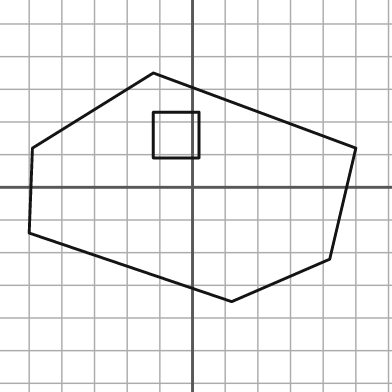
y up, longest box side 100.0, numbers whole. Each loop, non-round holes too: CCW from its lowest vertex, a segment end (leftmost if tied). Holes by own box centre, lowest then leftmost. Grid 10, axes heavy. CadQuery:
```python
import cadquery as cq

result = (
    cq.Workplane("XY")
    .moveTo(12.0, -35.0)
    .lineTo(42.0, -22.0)
    .lineTo(50.0, 12.0)
    .lineTo(-12.0, 35.0)
    .lineTo(-49.0, 12.0)
    .lineTo(-50.0, -14.0)
    .close()
    .moveTo(-12.0, 9.0)
    .lineTo(2.0, 9.0)
    .lineTo(2.0, 23.0)
    .lineTo(-12.0, 23.0)
    .close()
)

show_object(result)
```